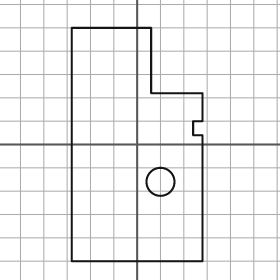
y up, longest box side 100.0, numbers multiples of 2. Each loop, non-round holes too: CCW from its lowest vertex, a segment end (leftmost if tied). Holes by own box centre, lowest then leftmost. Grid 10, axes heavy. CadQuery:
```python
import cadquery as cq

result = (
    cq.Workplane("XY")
    .moveTo(-28.0, -50.0)
    .lineTo(28.0, -50.0)
    .lineTo(28.0, 4.0)
    .lineTo(24.0, 4.0)
    .lineTo(24.0, 10.0)
    .lineTo(28.0, 10.0)
    .lineTo(28.0, 22.0)
    .lineTo(6.0, 22.0)
    .lineTo(6.0, 50.0)
    .lineTo(-28.0, 50.0)
    .close()
    .moveTo(10.0, -16.0)
    .circle(6.0)
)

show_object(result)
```